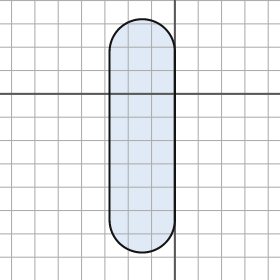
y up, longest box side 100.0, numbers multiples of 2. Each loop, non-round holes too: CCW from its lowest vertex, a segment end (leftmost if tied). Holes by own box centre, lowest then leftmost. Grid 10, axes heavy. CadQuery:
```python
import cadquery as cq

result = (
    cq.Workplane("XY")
    .moveTo(-28.0, -54.0)
    .threePointArc((-14.0, -68.0), (0.0, -54.0))
    .lineTo(0.0, 18.0)
    .threePointArc((-14.0, 32.0), (-28.0, 18.0))
    .close()
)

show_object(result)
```